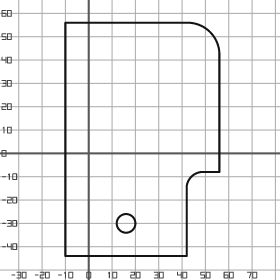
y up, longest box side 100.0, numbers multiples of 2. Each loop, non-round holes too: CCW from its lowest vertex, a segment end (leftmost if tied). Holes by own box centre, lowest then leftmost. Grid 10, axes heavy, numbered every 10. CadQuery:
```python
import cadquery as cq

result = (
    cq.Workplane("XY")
    .moveTo(-10.0, -44.0)
    .lineTo(42.0, -44.0)
    .lineTo(42.0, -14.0)
    .threePointArc((44.0, -10.0), (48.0, -8.0))
    .lineTo(56.0, -8.0)
    .lineTo(56.0, 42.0)
    .threePointArc((52.0, 52.0), (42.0, 56.0))
    .lineTo(-10.0, 56.0)
    .close()
    .moveTo(16.0, -30.0)
    .circle(4.0)
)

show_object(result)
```